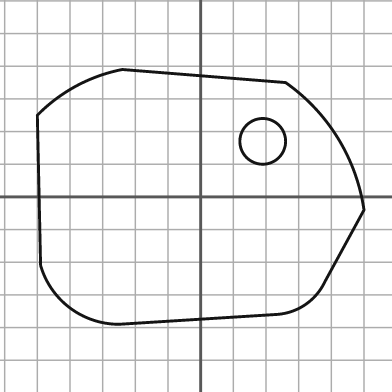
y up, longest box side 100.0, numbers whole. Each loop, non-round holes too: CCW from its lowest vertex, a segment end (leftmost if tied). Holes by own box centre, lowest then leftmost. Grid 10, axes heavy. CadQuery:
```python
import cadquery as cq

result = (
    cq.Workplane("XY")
    .moveTo(-25.0, -39.0)
    .lineTo(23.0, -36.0)
    .threePointArc((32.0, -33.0), (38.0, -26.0))
    .lineTo(50.0, -4.0)
    .threePointArc((42.0, 18.0), (26.0, 35.0))
    .lineTo(-24.0, 39.0)
    .threePointArc((-38.0, 34.0), (-50.0, 25.0))
    .lineTo(-49.0, -21.0)
    .threePointArc((-40.0, -34.0), (-25.0, -39.0))
    .close()
    .moveTo(19.0, 17.0)
    .circle(7.0)
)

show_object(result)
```